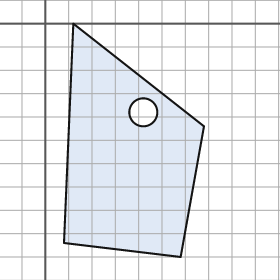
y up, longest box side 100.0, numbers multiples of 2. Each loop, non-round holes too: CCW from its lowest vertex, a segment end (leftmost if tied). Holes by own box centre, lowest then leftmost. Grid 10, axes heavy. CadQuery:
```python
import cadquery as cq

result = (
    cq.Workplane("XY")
    .moveTo(58.0, -100.0)
    .lineTo(68.0, -44.0)
    .lineTo(12.0, 0.0)
    .lineTo(8.0, -94.0)
    .close()
    .moveTo(42.0, -38.0)
    .circle(6.0)
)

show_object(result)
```